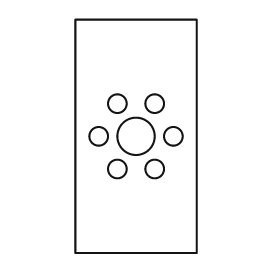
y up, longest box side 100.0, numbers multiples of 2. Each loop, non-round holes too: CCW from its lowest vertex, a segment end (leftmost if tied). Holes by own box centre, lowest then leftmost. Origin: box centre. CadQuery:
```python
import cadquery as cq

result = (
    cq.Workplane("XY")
    .moveTo(-26.0, -50.0)
    .lineTo(26.0, -50.0)
    .lineTo(26.0, 50.0)
    .lineTo(-26.0, 50.0)
    .close()
    .moveTo(-8.0, -14.0)
    .circle(4.0)
    .moveTo(8.0, -14.0)
    .circle(4.0)
    .moveTo(-16.0, 0.0)
    .circle(4.0)
    .moveTo(0.0, 0.0)
    .circle(8.0)
    .moveTo(16.0, 0.0)
    .circle(4.0)
    .moveTo(-8.0, 14.0)
    .circle(4.0)
    .moveTo(8.0, 14.0)
    .circle(4.0)
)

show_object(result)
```